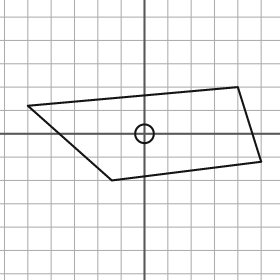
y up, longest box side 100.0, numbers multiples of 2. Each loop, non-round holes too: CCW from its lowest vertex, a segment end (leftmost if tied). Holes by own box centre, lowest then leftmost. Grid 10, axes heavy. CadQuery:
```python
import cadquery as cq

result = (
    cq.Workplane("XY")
    .moveTo(-14.0, -20.0)
    .lineTo(50.0, -12.0)
    .lineTo(40.0, 20.0)
    .lineTo(-50.0, 12.0)
    .close()
    .moveTo(0.0, 0.0)
    .circle(4.0)
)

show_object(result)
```